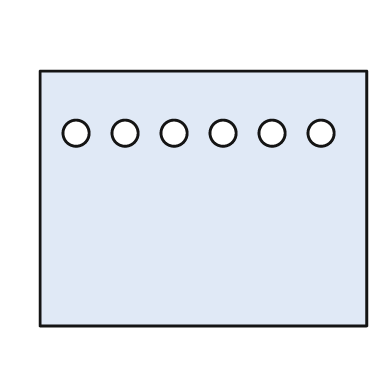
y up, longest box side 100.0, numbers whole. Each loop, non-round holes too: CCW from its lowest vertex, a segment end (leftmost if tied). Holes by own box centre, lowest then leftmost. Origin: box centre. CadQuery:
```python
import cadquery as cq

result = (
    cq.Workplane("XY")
    .moveTo(-50.0, -39.0)
    .lineTo(50.0, -39.0)
    .lineTo(50.0, 39.0)
    .lineTo(-50.0, 39.0)
    .close()
    .moveTo(-39.0, 20.0)
    .circle(4.0)
    .moveTo(-24.0, 20.0)
    .circle(4.0)
    .moveTo(-9.0, 20.0)
    .circle(4.0)
    .moveTo(6.0, 20.0)
    .circle(4.0)
    .moveTo(21.0, 20.0)
    .circle(4.0)
    .moveTo(36.0, 20.0)
    .circle(4.0)
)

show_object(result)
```